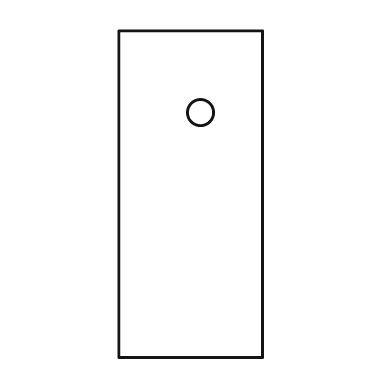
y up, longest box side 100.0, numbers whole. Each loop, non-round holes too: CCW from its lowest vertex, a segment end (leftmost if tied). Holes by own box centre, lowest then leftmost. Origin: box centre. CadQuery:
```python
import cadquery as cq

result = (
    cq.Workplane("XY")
    .moveTo(-22.0, -50.0)
    .lineTo(22.0, -50.0)
    .lineTo(22.0, 50.0)
    .lineTo(-22.0, 50.0)
    .close()
    .moveTo(3.0, 25.0)
    .circle(4.0)
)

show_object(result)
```